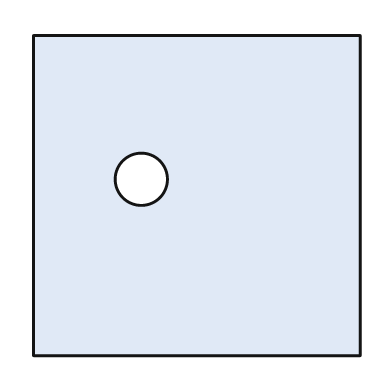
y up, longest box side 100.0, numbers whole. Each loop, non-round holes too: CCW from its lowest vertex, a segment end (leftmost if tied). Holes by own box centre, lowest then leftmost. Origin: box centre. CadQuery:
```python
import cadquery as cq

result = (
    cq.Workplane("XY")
    .moveTo(-50.0, -49.0)
    .lineTo(50.0, -49.0)
    .lineTo(50.0, 49.0)
    .lineTo(-50.0, 49.0)
    .close()
    .moveTo(-17.0, 5.0)
    .circle(8.0)
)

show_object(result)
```